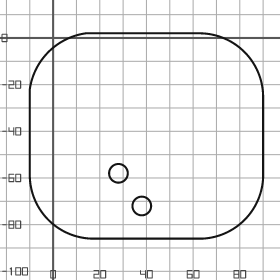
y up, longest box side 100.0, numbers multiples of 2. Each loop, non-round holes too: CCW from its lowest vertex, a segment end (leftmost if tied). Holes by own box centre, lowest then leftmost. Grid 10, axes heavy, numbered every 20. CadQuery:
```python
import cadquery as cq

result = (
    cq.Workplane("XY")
    .moveTo(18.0, -86.0)
    .lineTo(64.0, -86.0)
    .threePointArc((82.0, -78.0), (90.0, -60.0))
    .lineTo(90.0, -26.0)
    .threePointArc((82.0, -6.0), (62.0, 2.0))
    .lineTo(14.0, 2.0)
    .threePointArc((-2.0, -6.0), (-10.0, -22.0))
    .lineTo(-10.0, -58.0)
    .threePointArc((-2.0, -78.0), (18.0, -86.0))
    .close()
    .moveTo(38.0, -72.0)
    .circle(4.0)
    .moveTo(28.0, -58.0)
    .circle(4.0)
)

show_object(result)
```